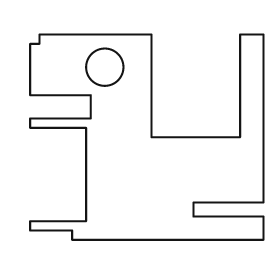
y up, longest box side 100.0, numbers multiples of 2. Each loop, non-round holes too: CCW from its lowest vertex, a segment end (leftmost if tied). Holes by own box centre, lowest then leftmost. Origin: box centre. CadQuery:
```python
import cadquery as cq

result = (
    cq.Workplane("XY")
    .moveTo(-32.0, -44.0)
    .lineTo(50.0, -44.0)
    .lineTo(50.0, -34.0)
    .lineTo(20.0, -34.0)
    .lineTo(20.0, -28.0)
    .lineTo(50.0, -28.0)
    .lineTo(50.0, 44.0)
    .lineTo(40.0, 44.0)
    .lineTo(40.0, 0.0)
    .lineTo(2.0, 0.0)
    .lineTo(2.0, 44.0)
    .lineTo(-46.0, 44.0)
    .lineTo(-46.0, 40.0)
    .lineTo(-50.0, 40.0)
    .lineTo(-50.0, 18.0)
    .lineTo(-24.0, 18.0)
    .lineTo(-24.0, 8.0)
    .lineTo(-50.0, 8.0)
    .lineTo(-50.0, 4.0)
    .lineTo(-26.0, 4.0)
    .lineTo(-26.0, -36.0)
    .lineTo(-50.0, -36.0)
    .lineTo(-50.0, -40.0)
    .lineTo(-32.0, -40.0)
    .close()
    .moveTo(-18.0, 30.0)
    .circle(8.0)
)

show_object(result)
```